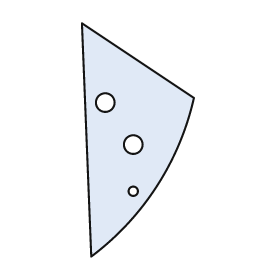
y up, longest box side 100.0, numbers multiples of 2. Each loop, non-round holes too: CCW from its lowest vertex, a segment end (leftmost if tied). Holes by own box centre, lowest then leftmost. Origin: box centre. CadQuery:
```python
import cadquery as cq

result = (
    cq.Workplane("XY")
    .moveTo(-20.0, -50.0)
    .threePointArc((8.0, -20.0), (24.0, 18.0))
    .lineTo(-24.0, 50.0)
    .close()
    .moveTo(-2.0, -22.0)
    .circle(2.0)
    .moveTo(-2.0, -2.0)
    .circle(4.0)
    .moveTo(-14.0, 16.0)
    .circle(4.0)
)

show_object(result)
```